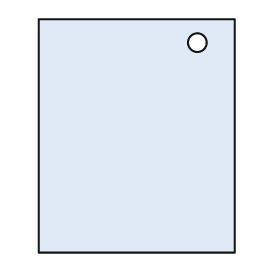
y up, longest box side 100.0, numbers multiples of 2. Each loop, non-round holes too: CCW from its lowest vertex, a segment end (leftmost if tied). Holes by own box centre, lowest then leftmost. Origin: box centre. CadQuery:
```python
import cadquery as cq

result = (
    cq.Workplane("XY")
    .moveTo(-42.0, -50.0)
    .lineTo(42.0, -50.0)
    .lineTo(42.0, 50.0)
    .lineTo(-42.0, 50.0)
    .close()
    .moveTo(26.0, 40.0)
    .circle(4.0)
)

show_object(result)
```